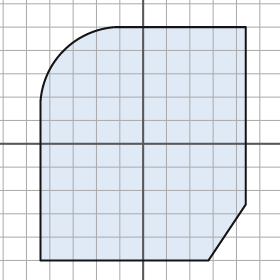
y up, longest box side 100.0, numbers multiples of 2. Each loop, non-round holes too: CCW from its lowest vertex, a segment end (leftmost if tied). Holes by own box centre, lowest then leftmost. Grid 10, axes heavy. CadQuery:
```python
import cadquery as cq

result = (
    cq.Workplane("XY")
    .moveTo(-44.0, -50.0)
    .lineTo(28.0, -50.0)
    .lineTo(44.0, -26.0)
    .lineTo(44.0, 50.0)
    .lineTo(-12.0, 50.0)
    .threePointArc((-34.0, 40.0), (-44.0, 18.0))
    .close()
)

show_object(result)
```